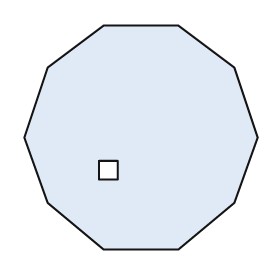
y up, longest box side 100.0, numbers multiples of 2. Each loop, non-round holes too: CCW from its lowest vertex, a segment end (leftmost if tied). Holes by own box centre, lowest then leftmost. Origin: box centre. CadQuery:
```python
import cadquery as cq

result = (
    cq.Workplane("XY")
    .moveTo(-16.0, -48.0)
    .lineTo(16.0, -48.0)
    .lineTo(40.0, -28.0)
    .lineTo(50.0, 0.0)
    .lineTo(40.0, 30.0)
    .lineTo(16.0, 48.0)
    .lineTo(-16.0, 48.0)
    .lineTo(-40.0, 30.0)
    .lineTo(-50.0, 0.0)
    .lineTo(-40.0, -28.0)
    .close()
    .moveTo(-18.0, -18.0)
    .lineTo(-10.0, -18.0)
    .lineTo(-10.0, -10.0)
    .lineTo(-18.0, -10.0)
    .close()
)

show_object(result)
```